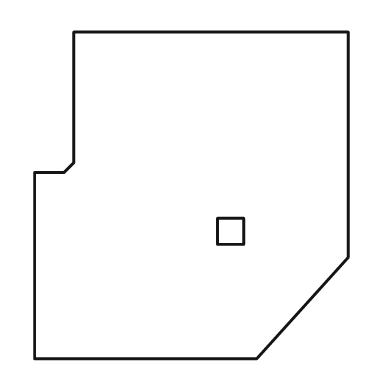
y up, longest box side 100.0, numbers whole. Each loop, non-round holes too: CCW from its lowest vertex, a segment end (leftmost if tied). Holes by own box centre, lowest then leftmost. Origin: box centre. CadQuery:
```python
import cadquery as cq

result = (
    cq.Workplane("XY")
    .moveTo(-48.0, -50.0)
    .lineTo(20.0, -50.0)
    .lineTo(48.0, -19.0)
    .lineTo(48.0, 50.0)
    .lineTo(-36.0, 50.0)
    .lineTo(-36.0, 10.0)
    .lineTo(-39.0, 7.0)
    .lineTo(-48.0, 7.0)
    .close()
    .moveTo(8.0, -15.0)
    .lineTo(16.0, -15.0)
    .lineTo(16.0, -7.0)
    .lineTo(8.0, -7.0)
    .close()
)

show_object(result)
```